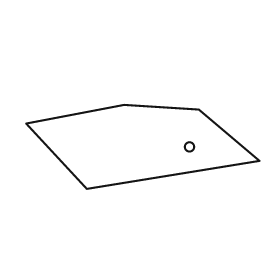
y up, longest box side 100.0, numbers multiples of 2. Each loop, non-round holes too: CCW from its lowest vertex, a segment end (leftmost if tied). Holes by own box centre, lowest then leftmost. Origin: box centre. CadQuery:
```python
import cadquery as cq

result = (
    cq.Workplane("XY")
    .moveTo(-24.0, -18.0)
    .lineTo(50.0, -6.0)
    .lineTo(24.0, 16.0)
    .lineTo(-8.0, 18.0)
    .lineTo(-50.0, 10.0)
    .close()
    .moveTo(20.0, 0.0)
    .circle(2.0)
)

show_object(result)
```